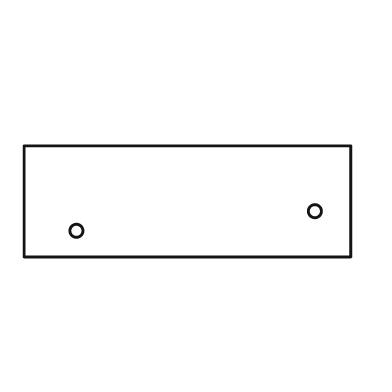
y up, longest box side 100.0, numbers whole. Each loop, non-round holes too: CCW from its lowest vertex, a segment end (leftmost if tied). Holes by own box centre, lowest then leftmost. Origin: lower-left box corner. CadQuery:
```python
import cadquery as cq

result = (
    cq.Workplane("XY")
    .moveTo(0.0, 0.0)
    .lineTo(100.0, 0.0)
    .lineTo(100.0, 34.0)
    .lineTo(0.0, 34.0)
    .close()
    .moveTo(16.0, 8.0)
    .circle(2.0)
    .moveTo(89.0, 14.0)
    .circle(2.0)
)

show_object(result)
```